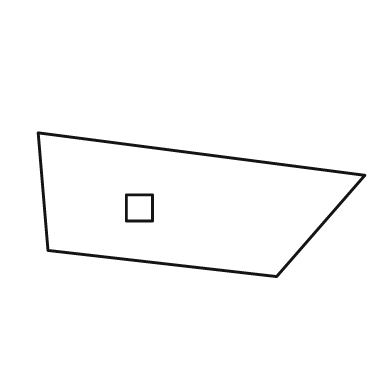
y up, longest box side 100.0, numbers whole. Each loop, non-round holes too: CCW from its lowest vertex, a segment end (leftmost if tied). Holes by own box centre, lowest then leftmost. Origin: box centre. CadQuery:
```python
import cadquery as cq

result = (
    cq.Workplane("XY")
    .moveTo(23.0, -22.0)
    .lineTo(50.0, 9.0)
    .lineTo(-50.0, 22.0)
    .lineTo(-47.0, -14.0)
    .close()
    .moveTo(-23.0, -5.0)
    .lineTo(-15.0, -5.0)
    .lineTo(-15.0, 3.0)
    .lineTo(-23.0, 3.0)
    .close()
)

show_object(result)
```